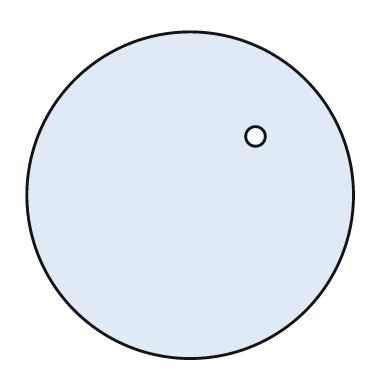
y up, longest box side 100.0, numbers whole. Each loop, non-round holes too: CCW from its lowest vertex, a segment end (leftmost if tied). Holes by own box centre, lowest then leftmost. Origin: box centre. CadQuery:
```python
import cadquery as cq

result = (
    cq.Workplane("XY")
    .moveTo(0.0, 0.0)
    .circle(50.0)
    .moveTo(20.0, 18.0)
    .circle(3.0)
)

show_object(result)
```